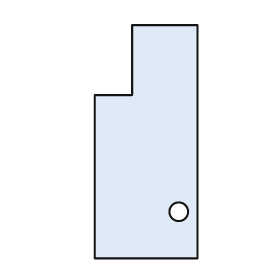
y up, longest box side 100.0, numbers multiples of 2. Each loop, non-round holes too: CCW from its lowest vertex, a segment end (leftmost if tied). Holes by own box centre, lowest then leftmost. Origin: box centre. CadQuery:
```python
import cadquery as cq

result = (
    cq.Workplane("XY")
    .moveTo(-22.0, -50.0)
    .lineTo(22.0, -50.0)
    .lineTo(22.0, 50.0)
    .lineTo(-6.0, 50.0)
    .lineTo(-6.0, 20.0)
    .lineTo(-22.0, 20.0)
    .close()
    .moveTo(14.0, -30.0)
    .circle(4.0)
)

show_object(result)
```